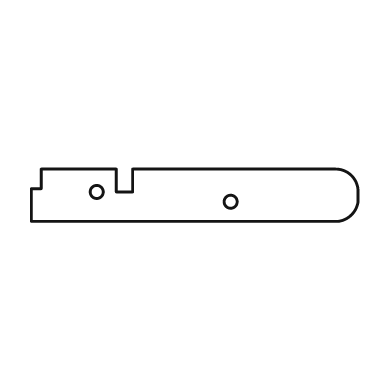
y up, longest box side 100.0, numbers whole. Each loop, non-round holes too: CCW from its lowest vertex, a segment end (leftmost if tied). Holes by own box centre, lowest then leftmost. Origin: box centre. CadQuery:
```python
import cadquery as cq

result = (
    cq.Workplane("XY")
    .moveTo(-50.0, -8.0)
    .lineTo(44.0, -8.0)
    .threePointArc((48.0, -6.0), (50.0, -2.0))
    .lineTo(50.0, 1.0)
    .threePointArc((48.0, 6.0), (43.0, 8.0))
    .lineTo(-19.0, 8.0)
    .lineTo(-19.0, 1.0)
    .lineTo(-24.0, 1.0)
    .lineTo(-24.0, 8.0)
    .lineTo(-47.0, 8.0)
    .lineTo(-47.0, 2.0)
    .lineTo(-50.0, 2.0)
    .close()
    .moveTo(11.0, -2.0)
    .circle(2.0)
    .moveTo(-30.0, 1.0)
    .circle(2.0)
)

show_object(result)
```